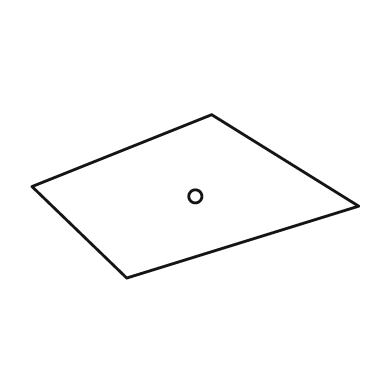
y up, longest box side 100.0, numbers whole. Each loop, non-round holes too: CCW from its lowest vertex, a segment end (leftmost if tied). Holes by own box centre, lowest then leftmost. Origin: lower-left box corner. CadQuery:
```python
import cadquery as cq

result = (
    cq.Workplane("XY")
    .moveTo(29.0, 0.0)
    .lineTo(100.0, 22.0)
    .lineTo(55.0, 50.0)
    .lineTo(0.0, 28.0)
    .close()
    .moveTo(50.0, 25.0)
    .circle(2.0)
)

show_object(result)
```